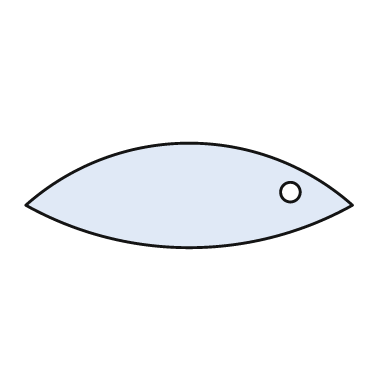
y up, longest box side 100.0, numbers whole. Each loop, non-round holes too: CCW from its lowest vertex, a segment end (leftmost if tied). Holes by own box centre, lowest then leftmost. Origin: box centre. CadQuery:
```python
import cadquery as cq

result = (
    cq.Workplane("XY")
    .moveTo(-50.0, -3.0)
    .threePointArc((0.0, -16.0), (50.0, -3.0))
    .threePointArc((0.0, 16.0), (-50.0, -3.0))
    .close()
    .moveTo(31.0, 1.0)
    .circle(3.0)
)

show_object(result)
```